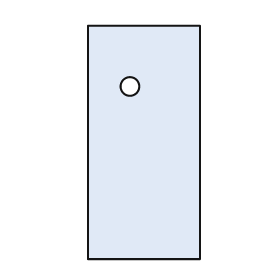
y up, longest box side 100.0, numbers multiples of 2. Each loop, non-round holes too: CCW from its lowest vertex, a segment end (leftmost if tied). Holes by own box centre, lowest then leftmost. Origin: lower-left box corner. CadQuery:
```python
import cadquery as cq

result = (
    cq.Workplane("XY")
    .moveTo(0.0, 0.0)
    .lineTo(48.0, 0.0)
    .lineTo(48.0, 100.0)
    .lineTo(0.0, 100.0)
    .close()
    .moveTo(18.0, 74.0)
    .circle(4.0)
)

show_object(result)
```